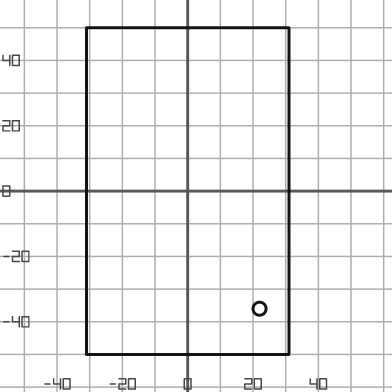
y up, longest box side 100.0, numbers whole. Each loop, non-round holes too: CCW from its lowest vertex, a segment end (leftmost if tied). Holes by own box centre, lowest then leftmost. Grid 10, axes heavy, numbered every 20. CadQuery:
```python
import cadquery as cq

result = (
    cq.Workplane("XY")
    .moveTo(-31.0, -50.0)
    .lineTo(31.0, -50.0)
    .lineTo(31.0, 50.0)
    .lineTo(-31.0, 50.0)
    .close()
    .moveTo(22.0, -36.0)
    .circle(2.0)
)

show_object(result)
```